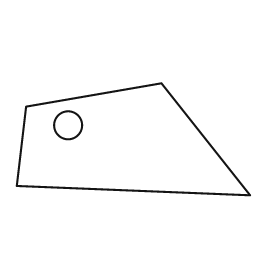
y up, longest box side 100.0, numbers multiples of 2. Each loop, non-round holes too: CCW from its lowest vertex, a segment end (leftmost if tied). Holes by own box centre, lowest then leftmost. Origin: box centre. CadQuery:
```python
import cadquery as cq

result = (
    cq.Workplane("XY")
    .moveTo(50.0, -24.0)
    .lineTo(12.0, 24.0)
    .lineTo(-46.0, 14.0)
    .lineTo(-50.0, -20.0)
    .close()
    .moveTo(-28.0, 6.0)
    .circle(6.0)
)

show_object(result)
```